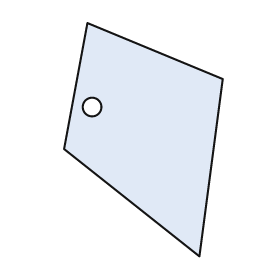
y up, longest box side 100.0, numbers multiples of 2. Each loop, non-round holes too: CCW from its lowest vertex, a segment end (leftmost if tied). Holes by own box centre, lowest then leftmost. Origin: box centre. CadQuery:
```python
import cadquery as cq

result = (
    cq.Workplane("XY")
    .moveTo(24.0, -50.0)
    .lineTo(34.0, 26.0)
    .lineTo(-24.0, 50.0)
    .lineTo(-34.0, -4.0)
    .close()
    .moveTo(-22.0, 14.0)
    .circle(4.0)
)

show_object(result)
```